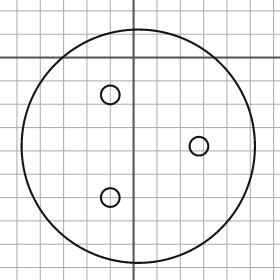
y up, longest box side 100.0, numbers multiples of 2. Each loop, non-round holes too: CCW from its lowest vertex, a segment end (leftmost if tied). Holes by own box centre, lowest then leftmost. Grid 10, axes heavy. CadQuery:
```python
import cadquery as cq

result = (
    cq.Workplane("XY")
    .moveTo(2.0, -38.0)
    .circle(50.0)
    .moveTo(-10.0, -60.0)
    .circle(4.0)
    .moveTo(28.0, -38.0)
    .circle(4.0)
    .moveTo(-10.0, -16.0)
    .circle(4.0)
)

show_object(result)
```